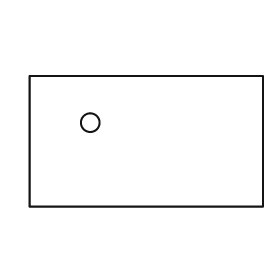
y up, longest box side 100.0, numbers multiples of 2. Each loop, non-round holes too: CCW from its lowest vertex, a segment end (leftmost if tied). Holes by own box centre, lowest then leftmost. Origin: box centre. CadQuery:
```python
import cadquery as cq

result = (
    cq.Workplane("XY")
    .moveTo(-50.0, -28.0)
    .lineTo(50.0, -28.0)
    .lineTo(50.0, 28.0)
    .lineTo(-50.0, 28.0)
    .close()
    .moveTo(-24.0, 8.0)
    .circle(4.0)
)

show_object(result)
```